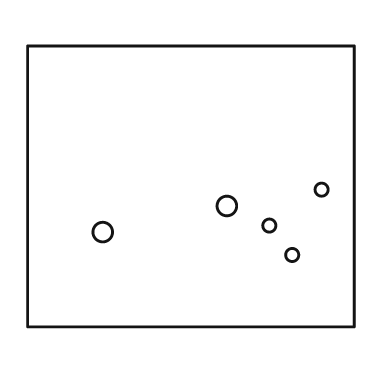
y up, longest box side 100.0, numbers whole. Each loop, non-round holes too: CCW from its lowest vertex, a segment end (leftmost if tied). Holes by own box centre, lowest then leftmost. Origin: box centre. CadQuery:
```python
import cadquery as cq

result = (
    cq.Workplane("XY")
    .moveTo(-50.0, -43.0)
    .lineTo(50.0, -43.0)
    .lineTo(50.0, 43.0)
    .lineTo(-50.0, 43.0)
    .close()
    .moveTo(31.0, -21.0)
    .circle(2.0)
    .moveTo(-27.0, -14.0)
    .circle(3.0)
    .moveTo(24.0, -12.0)
    .circle(2.0)
    .moveTo(11.0, -6.0)
    .circle(3.0)
    .moveTo(40.0, -1.0)
    .circle(2.0)
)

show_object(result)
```